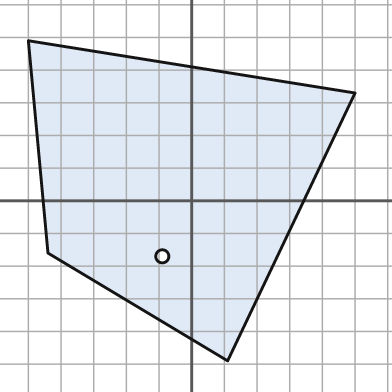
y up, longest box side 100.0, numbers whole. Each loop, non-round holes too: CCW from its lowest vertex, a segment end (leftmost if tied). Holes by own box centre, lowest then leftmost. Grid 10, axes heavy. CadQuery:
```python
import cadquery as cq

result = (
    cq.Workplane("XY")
    .moveTo(11.0, -49.0)
    .lineTo(50.0, 33.0)
    .lineTo(-50.0, 49.0)
    .lineTo(-44.0, -16.0)
    .close()
    .moveTo(-9.0, -17.0)
    .circle(2.0)
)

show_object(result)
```